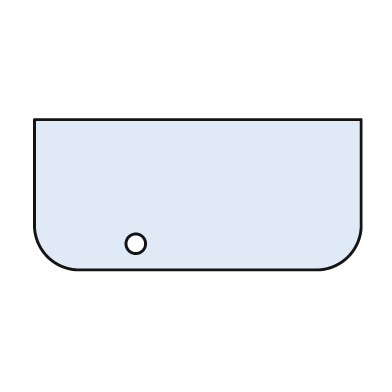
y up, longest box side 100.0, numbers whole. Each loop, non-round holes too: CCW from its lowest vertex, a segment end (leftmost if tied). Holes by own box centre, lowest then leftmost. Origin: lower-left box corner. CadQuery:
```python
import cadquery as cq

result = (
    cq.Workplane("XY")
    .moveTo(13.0, 0.0)
    .lineTo(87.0, 0.0)
    .threePointArc((96.0, 4.0), (100.0, 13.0))
    .lineTo(100.0, 46.0)
    .lineTo(0.0, 46.0)
    .lineTo(0.0, 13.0)
    .threePointArc((4.0, 4.0), (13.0, 0.0))
    .close()
    .moveTo(31.0, 8.0)
    .circle(3.0)
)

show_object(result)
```